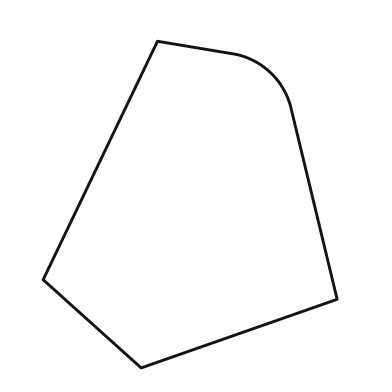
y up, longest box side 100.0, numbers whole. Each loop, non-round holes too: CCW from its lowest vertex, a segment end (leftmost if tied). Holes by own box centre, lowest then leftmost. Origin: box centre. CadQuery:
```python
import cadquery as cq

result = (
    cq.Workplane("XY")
    .moveTo(-15.0, -50.0)
    .lineTo(45.0, -29.0)
    .lineTo(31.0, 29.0)
    .threePointArc((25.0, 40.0), (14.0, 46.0))
    .lineTo(-10.0, 50.0)
    .lineTo(-45.0, -23.0)
    .close()
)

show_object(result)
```